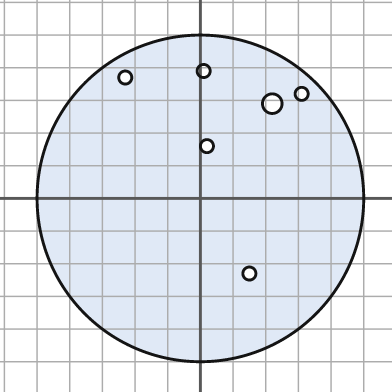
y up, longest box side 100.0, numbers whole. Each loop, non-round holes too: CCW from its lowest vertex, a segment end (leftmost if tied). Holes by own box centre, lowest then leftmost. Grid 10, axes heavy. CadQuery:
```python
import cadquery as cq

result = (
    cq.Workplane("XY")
    .moveTo(0.0, 0.0)
    .circle(50.0)
    .moveTo(15.0, -23.0)
    .circle(2.0)
    .moveTo(2.0, 16.0)
    .circle(2.0)
    .moveTo(22.0, 29.0)
    .circle(3.0)
    .moveTo(31.0, 32.0)
    .circle(2.0)
    .moveTo(-23.0, 37.0)
    .circle(2.0)
    .moveTo(1.0, 39.0)
    .circle(2.0)
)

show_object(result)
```